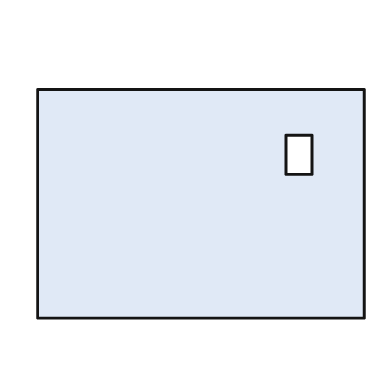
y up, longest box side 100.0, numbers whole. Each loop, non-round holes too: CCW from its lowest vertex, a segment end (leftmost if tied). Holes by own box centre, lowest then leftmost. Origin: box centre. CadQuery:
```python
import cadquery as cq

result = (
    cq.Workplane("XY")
    .moveTo(-50.0, -35.0)
    .lineTo(50.0, -35.0)
    .lineTo(50.0, 35.0)
    .lineTo(-50.0, 35.0)
    .close()
    .moveTo(26.0, 9.0)
    .lineTo(34.0, 9.0)
    .lineTo(34.0, 21.0)
    .lineTo(26.0, 21.0)
    .close()
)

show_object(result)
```